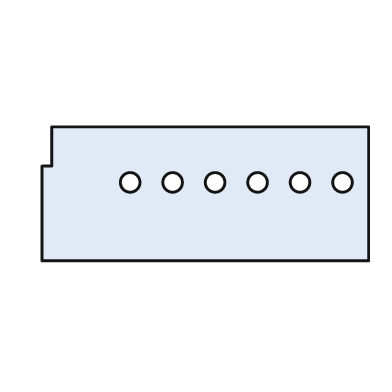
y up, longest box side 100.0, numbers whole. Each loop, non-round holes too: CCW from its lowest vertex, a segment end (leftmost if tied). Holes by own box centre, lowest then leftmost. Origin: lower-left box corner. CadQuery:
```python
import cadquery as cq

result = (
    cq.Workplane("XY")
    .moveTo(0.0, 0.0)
    .lineTo(100.0, 0.0)
    .lineTo(100.0, 41.0)
    .lineTo(3.0, 41.0)
    .lineTo(3.0, 29.0)
    .lineTo(0.0, 29.0)
    .close()
    .moveTo(27.0, 24.0)
    .circle(3.0)
    .moveTo(40.0, 24.0)
    .circle(3.0)
    .moveTo(53.0, 24.0)
    .circle(3.0)
    .moveTo(66.0, 24.0)
    .circle(3.0)
    .moveTo(79.0, 24.0)
    .circle(3.0)
    .moveTo(92.0, 24.0)
    .circle(3.0)
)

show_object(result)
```